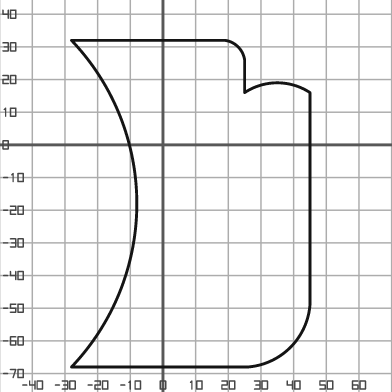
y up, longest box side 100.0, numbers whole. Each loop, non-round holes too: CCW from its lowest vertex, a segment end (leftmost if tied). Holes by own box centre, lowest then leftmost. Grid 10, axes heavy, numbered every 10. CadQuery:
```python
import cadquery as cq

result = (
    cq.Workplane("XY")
    .moveTo(-28.0, -68.0)
    .lineTo(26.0, -68.0)
    .threePointArc((39.0, -62.0), (45.0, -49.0))
    .lineTo(45.0, 16.0)
    .threePointArc((35.0, 19.0), (25.0, 16.0))
    .lineTo(25.0, 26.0)
    .threePointArc((23.0, 30.0), (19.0, 32.0))
    .lineTo(-28.0, 32.0)
    .threePointArc((-8.0, -18.0), (-28.0, -68.0))
    .close()
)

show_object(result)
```